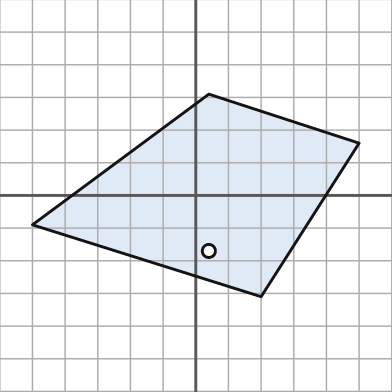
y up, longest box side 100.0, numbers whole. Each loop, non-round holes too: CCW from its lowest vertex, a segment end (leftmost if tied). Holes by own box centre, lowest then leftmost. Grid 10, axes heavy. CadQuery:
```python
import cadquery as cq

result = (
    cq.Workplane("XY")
    .moveTo(20.0, -31.0)
    .lineTo(50.0, 16.0)
    .lineTo(4.0, 31.0)
    .lineTo(-50.0, -9.0)
    .close()
    .moveTo(4.0, -17.0)
    .circle(2.0)
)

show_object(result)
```